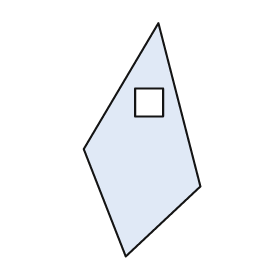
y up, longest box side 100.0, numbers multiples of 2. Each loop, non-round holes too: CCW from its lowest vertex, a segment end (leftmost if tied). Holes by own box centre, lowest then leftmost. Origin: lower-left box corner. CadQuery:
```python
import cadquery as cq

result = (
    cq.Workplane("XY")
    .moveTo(18.0, 0.0)
    .lineTo(50.0, 30.0)
    .lineTo(32.0, 100.0)
    .lineTo(0.0, 46.0)
    .close()
    .moveTo(22.0, 60.0)
    .lineTo(34.0, 60.0)
    .lineTo(34.0, 72.0)
    .lineTo(22.0, 72.0)
    .close()
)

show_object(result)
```